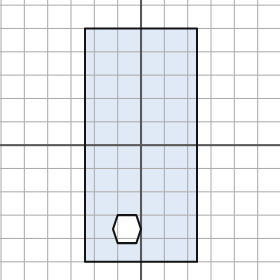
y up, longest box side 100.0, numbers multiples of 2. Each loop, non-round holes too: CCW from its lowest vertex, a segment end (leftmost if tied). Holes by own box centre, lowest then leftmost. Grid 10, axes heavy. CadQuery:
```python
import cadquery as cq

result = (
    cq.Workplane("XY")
    .moveTo(-24.0, -50.0)
    .lineTo(24.0, -50.0)
    .lineTo(24.0, 50.0)
    .lineTo(-24.0, 50.0)
    .close()
    .moveTo(-10.0, -42.0)
    .lineTo(-2.0, -42.0)
    .lineTo(0.0, -36.0)
    .lineTo(-2.0, -30.0)
    .lineTo(-10.0, -30.0)
    .lineTo(-12.0, -36.0)
    .close()
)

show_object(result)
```